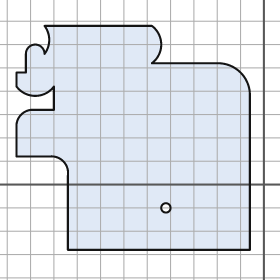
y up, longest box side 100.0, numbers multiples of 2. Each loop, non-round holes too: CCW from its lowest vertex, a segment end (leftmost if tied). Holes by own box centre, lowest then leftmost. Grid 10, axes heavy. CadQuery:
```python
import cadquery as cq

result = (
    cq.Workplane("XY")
    .moveTo(-84.0, -28.0)
    .lineTo(-6.0, -28.0)
    .lineTo(-6.0, 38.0)
    .threePointArc((-10.0, 48.0), (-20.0, 52.0))
    .lineTo(-48.0, 52.0)
    .threePointArc((-44.0, 60.0), (-48.0, 68.0))
    .lineTo(-94.0, 68.0)
    .threePointArc((-92.0, 62.0), (-94.0, 56.0))
    .threePointArc((-98.0, 60.0), (-102.0, 56.0))
    .lineTo(-102.0, 48.0)
    .lineTo(-106.0, 48.0)
    .lineTo(-106.0, 42.0)
    .threePointArc((-98.0, 38.0), (-90.0, 42.0))
    .lineTo(-90.0, 32.0)
    .lineTo(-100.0, 32.0)
    .threePointArc((-104.0, 30.0), (-106.0, 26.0))
    .lineTo(-106.0, 12.0)
    .lineTo(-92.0, 12.0)
    .threePointArc((-86.0, 10.0), (-84.0, 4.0))
    .close()
    .moveTo(-42.0, -10.0)
    .circle(2.0)
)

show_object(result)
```